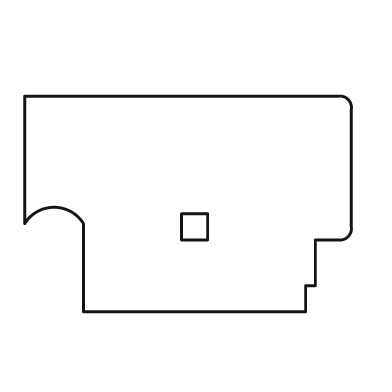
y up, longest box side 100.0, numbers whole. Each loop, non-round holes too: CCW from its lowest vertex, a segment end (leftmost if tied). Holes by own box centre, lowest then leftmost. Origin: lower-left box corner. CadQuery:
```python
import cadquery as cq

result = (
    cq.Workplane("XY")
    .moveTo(18.0, 0.0)
    .lineTo(86.0, 0.0)
    .lineTo(86.0, 8.0)
    .lineTo(89.0, 8.0)
    .lineTo(89.0, 22.0)
    .lineTo(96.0, 22.0)
    .threePointArc((99.0, 23.0), (100.0, 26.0))
    .lineTo(100.0, 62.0)
    .threePointArc((99.0, 65.0), (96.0, 66.0))
    .lineTo(0.0, 66.0)
    .lineTo(0.0, 27.0)
    .threePointArc((9.0, 32.0), (18.0, 27.0))
    .close()
    .moveTo(48.0, 22.0)
    .lineTo(56.0, 22.0)
    .lineTo(56.0, 30.0)
    .lineTo(48.0, 30.0)
    .close()
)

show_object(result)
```